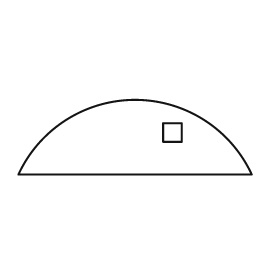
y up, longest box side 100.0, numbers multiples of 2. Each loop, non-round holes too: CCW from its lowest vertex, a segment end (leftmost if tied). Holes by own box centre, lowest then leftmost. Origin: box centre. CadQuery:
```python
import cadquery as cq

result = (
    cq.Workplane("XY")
    .moveTo(-50.0, -16.0)
    .lineTo(50.0, -16.0)
    .threePointArc((0.0, 16.0), (-50.0, -16.0))
    .close()
    .moveTo(12.0, -2.0)
    .lineTo(20.0, -2.0)
    .lineTo(20.0, 6.0)
    .lineTo(12.0, 6.0)
    .close()
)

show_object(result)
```